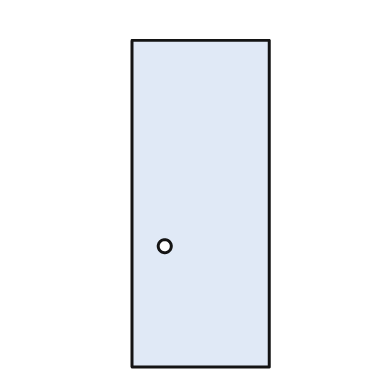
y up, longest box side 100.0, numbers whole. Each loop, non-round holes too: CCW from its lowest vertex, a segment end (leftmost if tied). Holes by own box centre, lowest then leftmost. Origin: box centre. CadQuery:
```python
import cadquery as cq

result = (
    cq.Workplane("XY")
    .moveTo(-21.0, -50.0)
    .lineTo(21.0, -50.0)
    .lineTo(21.0, 50.0)
    .lineTo(-21.0, 50.0)
    .close()
    .moveTo(-11.0, -13.0)
    .circle(2.0)
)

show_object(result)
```